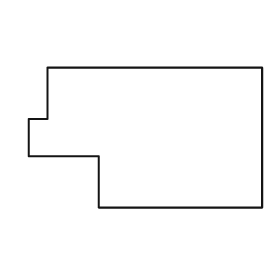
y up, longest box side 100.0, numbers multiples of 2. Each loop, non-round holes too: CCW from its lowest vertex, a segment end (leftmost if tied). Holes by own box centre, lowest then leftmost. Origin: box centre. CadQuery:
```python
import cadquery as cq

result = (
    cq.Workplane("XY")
    .moveTo(-20.0, -30.0)
    .lineTo(50.0, -30.0)
    .lineTo(50.0, 30.0)
    .lineTo(-42.0, 30.0)
    .lineTo(-42.0, 8.0)
    .lineTo(-50.0, 8.0)
    .lineTo(-50.0, -8.0)
    .lineTo(-20.0, -8.0)
    .close()
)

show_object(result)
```